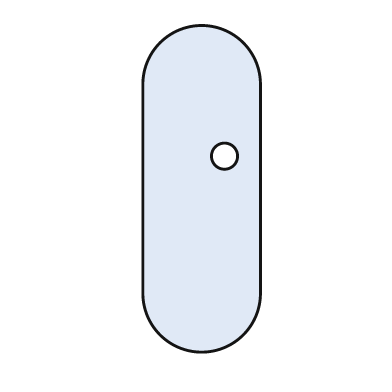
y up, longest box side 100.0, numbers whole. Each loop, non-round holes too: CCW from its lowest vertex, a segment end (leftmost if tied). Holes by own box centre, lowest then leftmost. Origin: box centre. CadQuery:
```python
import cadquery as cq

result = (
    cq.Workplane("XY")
    .moveTo(-18.0, -32.0)
    .threePointArc((0.0, -50.0), (18.0, -32.0))
    .lineTo(18.0, 32.0)
    .threePointArc((0.0, 50.0), (-18.0, 32.0))
    .close()
    .moveTo(7.0, 10.0)
    .circle(4.0)
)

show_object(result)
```